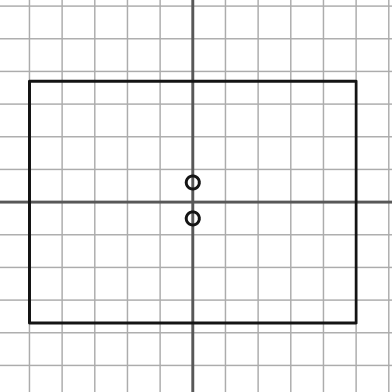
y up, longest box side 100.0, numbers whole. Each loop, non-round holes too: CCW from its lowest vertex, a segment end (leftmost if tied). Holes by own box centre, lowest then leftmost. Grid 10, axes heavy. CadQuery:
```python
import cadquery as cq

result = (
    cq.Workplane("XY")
    .moveTo(-50.0, -37.0)
    .lineTo(50.0, -37.0)
    .lineTo(50.0, 37.0)
    .lineTo(-50.0, 37.0)
    .close()
    .moveTo(0.0, -5.0)
    .circle(2.0)
    .moveTo(0.0, 6.0)
    .circle(2.0)
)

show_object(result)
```